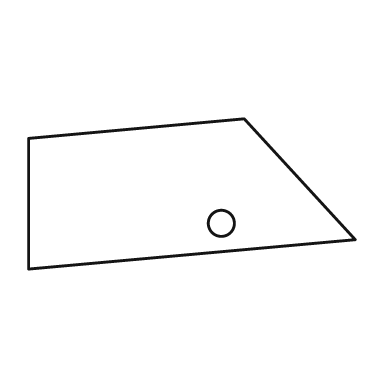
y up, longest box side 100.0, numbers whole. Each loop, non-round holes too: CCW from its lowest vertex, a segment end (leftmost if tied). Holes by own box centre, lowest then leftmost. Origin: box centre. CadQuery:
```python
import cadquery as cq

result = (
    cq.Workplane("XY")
    .moveTo(-50.0, -23.0)
    .lineTo(50.0, -14.0)
    .lineTo(16.0, 23.0)
    .lineTo(-50.0, 17.0)
    .close()
    .moveTo(9.0, -9.0)
    .circle(4.0)
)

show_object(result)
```